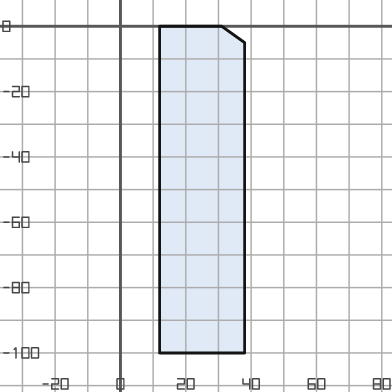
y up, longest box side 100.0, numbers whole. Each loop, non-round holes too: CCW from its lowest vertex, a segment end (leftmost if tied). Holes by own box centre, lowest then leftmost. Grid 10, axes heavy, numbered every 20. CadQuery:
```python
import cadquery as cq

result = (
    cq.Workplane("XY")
    .moveTo(12.0, -100.0)
    .lineTo(38.0, -100.0)
    .lineTo(38.0, -5.0)
    .lineTo(31.0, 0.0)
    .lineTo(12.0, 0.0)
    .close()
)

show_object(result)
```